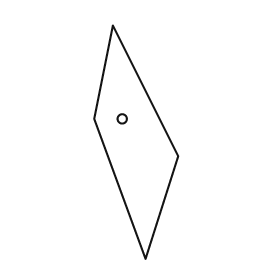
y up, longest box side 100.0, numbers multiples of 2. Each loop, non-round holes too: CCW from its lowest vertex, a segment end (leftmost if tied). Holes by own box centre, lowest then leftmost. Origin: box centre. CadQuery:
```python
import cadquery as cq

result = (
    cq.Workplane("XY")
    .moveTo(4.0, -50.0)
    .lineTo(18.0, -6.0)
    .lineTo(-10.0, 50.0)
    .lineTo(-18.0, 10.0)
    .close()
    .moveTo(-6.0, 10.0)
    .circle(2.0)
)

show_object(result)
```